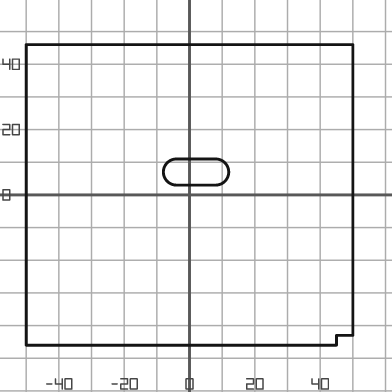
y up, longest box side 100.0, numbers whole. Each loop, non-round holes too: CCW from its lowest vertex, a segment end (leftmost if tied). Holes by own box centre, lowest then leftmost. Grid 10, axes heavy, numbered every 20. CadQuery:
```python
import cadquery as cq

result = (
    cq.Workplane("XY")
    .moveTo(-50.0, -46.0)
    .lineTo(45.0, -46.0)
    .lineTo(45.0, -43.0)
    .lineTo(50.0, -43.0)
    .lineTo(50.0, 46.0)
    .lineTo(-50.0, 46.0)
    .close()
    .moveTo(-4.0, 3.0)
    .lineTo(8.0, 3.0)
    .threePointArc((12.0, 7.0), (8.0, 11.0))
    .lineTo(-4.0, 11.0)
    .threePointArc((-8.0, 7.0), (-4.0, 3.0))
    .close()
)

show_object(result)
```